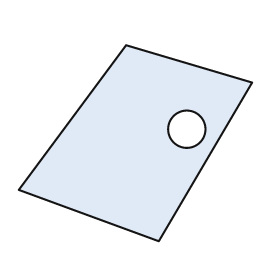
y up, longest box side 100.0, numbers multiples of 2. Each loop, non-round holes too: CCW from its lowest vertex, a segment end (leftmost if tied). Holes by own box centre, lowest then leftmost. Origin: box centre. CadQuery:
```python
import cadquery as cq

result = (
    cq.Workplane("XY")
    .moveTo(10.0, -42.0)
    .lineTo(50.0, 26.0)
    .lineTo(-4.0, 42.0)
    .lineTo(-50.0, -20.0)
    .close()
    .moveTo(22.0, 6.0)
    .circle(8.0)
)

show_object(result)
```